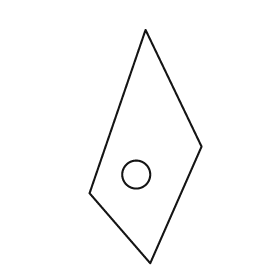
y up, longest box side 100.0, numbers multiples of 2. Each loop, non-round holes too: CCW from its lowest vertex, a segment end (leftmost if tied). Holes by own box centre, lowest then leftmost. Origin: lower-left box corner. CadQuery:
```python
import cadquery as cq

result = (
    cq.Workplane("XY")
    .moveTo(26.0, 0.0)
    .lineTo(48.0, 50.0)
    .lineTo(24.0, 100.0)
    .lineTo(0.0, 30.0)
    .close()
    .moveTo(20.0, 38.0)
    .circle(6.0)
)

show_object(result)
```